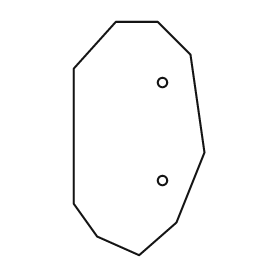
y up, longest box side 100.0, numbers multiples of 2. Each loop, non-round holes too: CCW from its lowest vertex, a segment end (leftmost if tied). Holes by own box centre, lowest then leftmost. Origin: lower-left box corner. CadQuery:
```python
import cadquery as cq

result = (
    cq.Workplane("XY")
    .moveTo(28.0, 0.0)
    .lineTo(44.0, 14.0)
    .lineTo(56.0, 44.0)
    .lineTo(50.0, 86.0)
    .lineTo(36.0, 100.0)
    .lineTo(18.0, 100.0)
    .lineTo(0.0, 80.0)
    .lineTo(0.0, 22.0)
    .lineTo(10.0, 8.0)
    .close()
    .moveTo(38.0, 32.0)
    .circle(2.0)
    .moveTo(38.0, 74.0)
    .circle(2.0)
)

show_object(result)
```